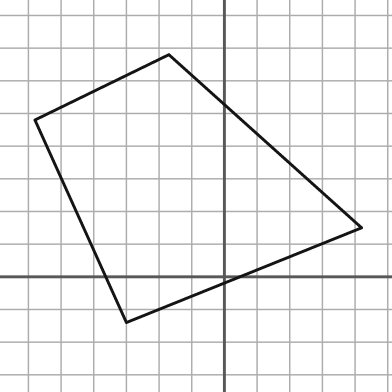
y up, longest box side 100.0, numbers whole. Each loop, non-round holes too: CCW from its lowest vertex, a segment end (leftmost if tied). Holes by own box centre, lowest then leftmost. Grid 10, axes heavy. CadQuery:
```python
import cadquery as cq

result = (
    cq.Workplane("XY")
    .moveTo(-30.0, -14.0)
    .lineTo(42.0, 15.0)
    .lineTo(-17.0, 68.0)
    .lineTo(-58.0, 48.0)
    .close()
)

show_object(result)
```